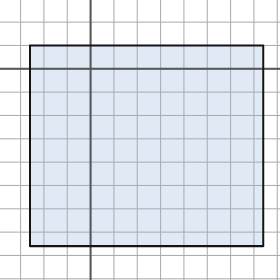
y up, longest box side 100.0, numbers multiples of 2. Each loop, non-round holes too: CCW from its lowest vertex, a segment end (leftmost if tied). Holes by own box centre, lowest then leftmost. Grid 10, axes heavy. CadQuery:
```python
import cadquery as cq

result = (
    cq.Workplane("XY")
    .moveTo(-26.0, -76.0)
    .lineTo(74.0, -76.0)
    .lineTo(74.0, 10.0)
    .lineTo(-26.0, 10.0)
    .close()
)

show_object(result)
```